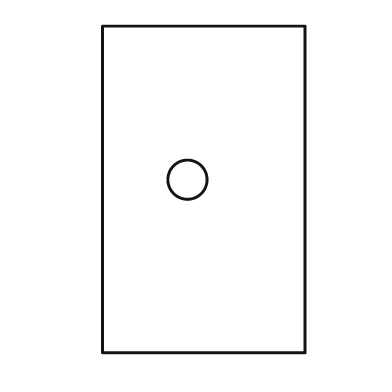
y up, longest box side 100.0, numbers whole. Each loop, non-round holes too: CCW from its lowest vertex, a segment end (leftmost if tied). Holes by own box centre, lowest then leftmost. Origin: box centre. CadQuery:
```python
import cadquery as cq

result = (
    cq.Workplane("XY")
    .moveTo(-31.0, -50.0)
    .lineTo(31.0, -50.0)
    .lineTo(31.0, 50.0)
    .lineTo(-31.0, 50.0)
    .close()
    .moveTo(-5.0, 3.0)
    .circle(6.0)
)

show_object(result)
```